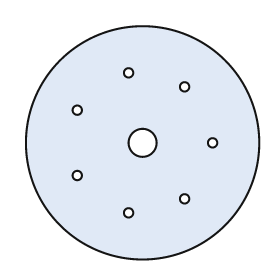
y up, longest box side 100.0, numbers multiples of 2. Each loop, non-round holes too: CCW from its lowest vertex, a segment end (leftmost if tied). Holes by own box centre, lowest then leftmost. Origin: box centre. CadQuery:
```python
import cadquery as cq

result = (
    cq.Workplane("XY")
    .moveTo(0.0, 0.0)
    .circle(50.0)
    .moveTo(-6.0, -30.0)
    .circle(2.0)
    .moveTo(18.0, -24.0)
    .circle(2.0)
    .moveTo(-28.0, -14.0)
    .circle(2.0)
    .moveTo(0.0, 0.0)
    .circle(6.0)
    .moveTo(30.0, 0.0)
    .circle(2.0)
    .moveTo(-28.0, 14.0)
    .circle(2.0)
    .moveTo(18.0, 24.0)
    .circle(2.0)
    .moveTo(-6.0, 30.0)
    .circle(2.0)
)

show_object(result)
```